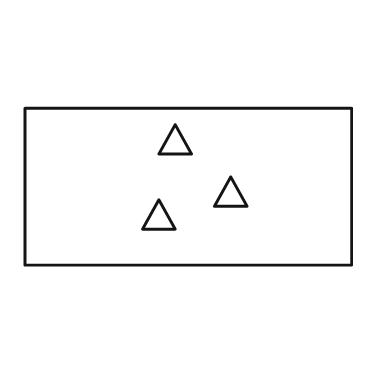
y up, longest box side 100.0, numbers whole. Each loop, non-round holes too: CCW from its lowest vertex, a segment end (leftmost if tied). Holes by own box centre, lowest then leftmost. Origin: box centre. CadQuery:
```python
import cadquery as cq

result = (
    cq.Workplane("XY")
    .moveTo(-50.0, -24.0)
    .lineTo(50.0, -24.0)
    .lineTo(50.0, 24.0)
    .lineTo(-50.0, 24.0)
    .close()
    .moveTo(-14.0, -13.0)
    .lineTo(-4.0, -13.0)
    .lineTo(-9.0, -4.0)
    .close()
    .moveTo(8.0, -6.0)
    .lineTo(18.0, -6.0)
    .lineTo(13.0, 3.0)
    .close()
    .moveTo(-9.0, 10.0)
    .lineTo(1.0, 10.0)
    .lineTo(-4.0, 19.0)
    .close()
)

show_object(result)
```